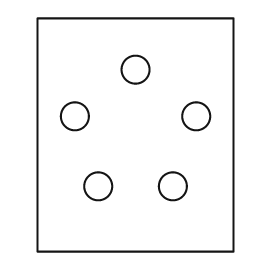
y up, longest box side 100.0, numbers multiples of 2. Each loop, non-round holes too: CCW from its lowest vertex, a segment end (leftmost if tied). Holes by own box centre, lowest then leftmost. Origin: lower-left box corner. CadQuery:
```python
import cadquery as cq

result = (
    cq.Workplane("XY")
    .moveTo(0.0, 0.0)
    .lineTo(84.0, 0.0)
    .lineTo(84.0, 100.0)
    .lineTo(0.0, 100.0)
    .close()
    .moveTo(26.0, 28.0)
    .circle(6.0)
    .moveTo(58.0, 28.0)
    .circle(6.0)
    .moveTo(16.0, 58.0)
    .circle(6.0)
    .moveTo(68.0, 58.0)
    .circle(6.0)
    .moveTo(42.0, 78.0)
    .circle(6.0)
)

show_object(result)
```